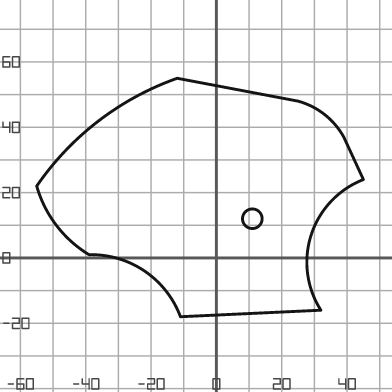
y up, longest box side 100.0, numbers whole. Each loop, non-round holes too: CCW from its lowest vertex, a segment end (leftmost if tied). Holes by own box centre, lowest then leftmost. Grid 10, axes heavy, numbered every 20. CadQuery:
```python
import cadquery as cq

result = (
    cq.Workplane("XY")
    .moveTo(-11.0, -18.0)
    .lineTo(32.0, -16.0)
    .threePointArc((29.0, 7.0), (45.0, 24.0))
    .lineTo(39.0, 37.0)
    .threePointArc((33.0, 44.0), (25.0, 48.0))
    .lineTo(-12.0, 55.0)
    .threePointArc((-36.0, 42.0), (-55.0, 22.0))
    .threePointArc((-49.0, 10.0), (-39.0, 1.0))
    .threePointArc((-22.0, -4.0), (-11.0, -18.0))
    .close()
    .moveTo(11.0, 12.0)
    .circle(3.0)
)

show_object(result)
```